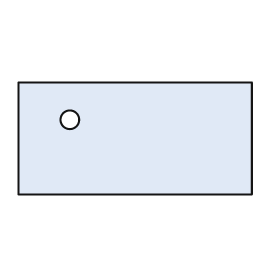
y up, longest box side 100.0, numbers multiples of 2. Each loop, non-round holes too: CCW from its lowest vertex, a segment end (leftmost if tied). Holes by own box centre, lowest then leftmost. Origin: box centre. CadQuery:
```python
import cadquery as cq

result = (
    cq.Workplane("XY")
    .moveTo(-50.0, -24.0)
    .lineTo(50.0, -24.0)
    .lineTo(50.0, 24.0)
    .lineTo(-50.0, 24.0)
    .close()
    .moveTo(-28.0, 8.0)
    .circle(4.0)
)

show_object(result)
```